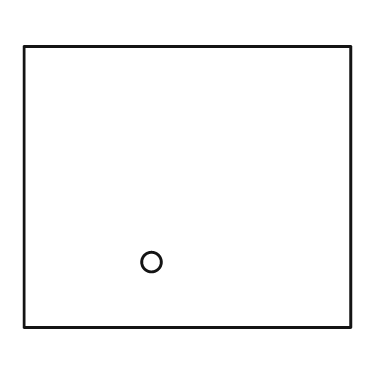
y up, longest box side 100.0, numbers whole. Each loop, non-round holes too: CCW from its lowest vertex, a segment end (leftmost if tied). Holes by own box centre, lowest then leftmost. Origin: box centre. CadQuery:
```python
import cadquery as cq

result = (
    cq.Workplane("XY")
    .moveTo(-50.0, -43.0)
    .lineTo(50.0, -43.0)
    .lineTo(50.0, 43.0)
    .lineTo(-50.0, 43.0)
    .close()
    .moveTo(-11.0, -23.0)
    .circle(3.0)
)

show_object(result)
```